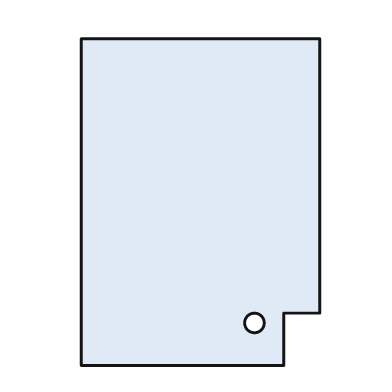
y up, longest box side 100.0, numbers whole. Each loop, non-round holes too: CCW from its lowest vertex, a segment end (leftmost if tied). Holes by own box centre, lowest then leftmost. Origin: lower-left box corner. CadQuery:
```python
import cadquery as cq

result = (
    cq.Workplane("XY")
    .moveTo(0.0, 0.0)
    .lineTo(62.0, 0.0)
    .lineTo(62.0, 16.0)
    .lineTo(73.0, 16.0)
    .lineTo(73.0, 100.0)
    .lineTo(0.0, 100.0)
    .close()
    .moveTo(53.0, 13.0)
    .circle(3.0)
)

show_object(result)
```